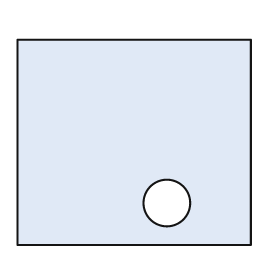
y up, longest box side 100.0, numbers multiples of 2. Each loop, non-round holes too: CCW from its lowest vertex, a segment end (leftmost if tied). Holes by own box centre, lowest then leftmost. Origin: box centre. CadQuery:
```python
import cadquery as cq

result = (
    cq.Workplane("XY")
    .moveTo(-50.0, -44.0)
    .lineTo(50.0, -44.0)
    .lineTo(50.0, 44.0)
    .lineTo(-50.0, 44.0)
    .close()
    .moveTo(14.0, -26.0)
    .circle(10.0)
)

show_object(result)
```